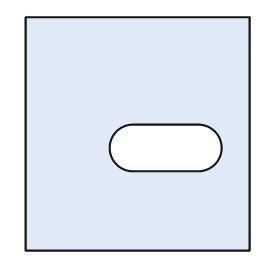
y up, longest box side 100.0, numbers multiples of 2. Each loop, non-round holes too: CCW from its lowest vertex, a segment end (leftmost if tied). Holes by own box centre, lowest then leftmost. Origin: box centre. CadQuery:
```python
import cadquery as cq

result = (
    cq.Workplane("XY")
    .moveTo(-48.0, -50.0)
    .lineTo(48.0, -50.0)
    .lineTo(48.0, 50.0)
    .lineTo(-48.0, 50.0)
    .close()
    .moveTo(-2.0, -16.0)
    .lineTo(26.0, -16.0)
    .threePointArc((36.0, -6.0), (26.0, 4.0))
    .lineTo(-2.0, 4.0)
    .threePointArc((-12.0, -6.0), (-2.0, -16.0))
    .close()
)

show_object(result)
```